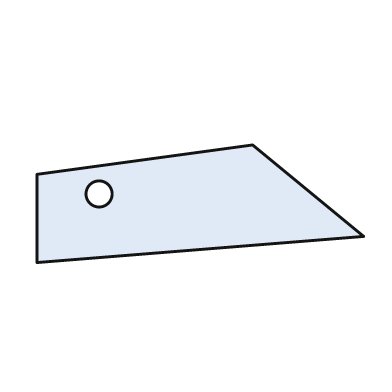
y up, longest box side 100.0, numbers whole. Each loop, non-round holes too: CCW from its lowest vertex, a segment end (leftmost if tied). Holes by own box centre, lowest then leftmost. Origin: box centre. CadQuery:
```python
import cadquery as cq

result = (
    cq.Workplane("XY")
    .moveTo(-50.0, -18.0)
    .lineTo(50.0, -10.0)
    .lineTo(16.0, 18.0)
    .lineTo(-50.0, 9.0)
    .close()
    .moveTo(-31.0, 3.0)
    .circle(4.0)
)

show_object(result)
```